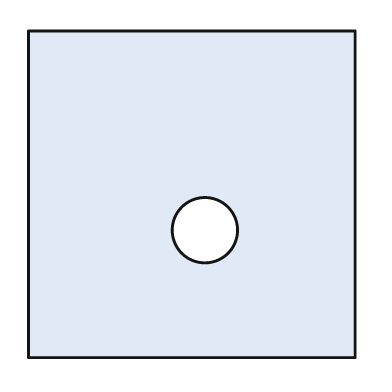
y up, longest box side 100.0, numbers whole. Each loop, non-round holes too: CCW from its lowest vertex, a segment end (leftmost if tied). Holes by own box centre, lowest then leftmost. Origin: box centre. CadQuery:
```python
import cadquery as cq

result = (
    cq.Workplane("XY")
    .moveTo(-50.0, -50.0)
    .lineTo(50.0, -50.0)
    .lineTo(50.0, 50.0)
    .lineTo(-50.0, 50.0)
    .close()
    .moveTo(4.0, -11.0)
    .circle(10.0)
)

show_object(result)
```